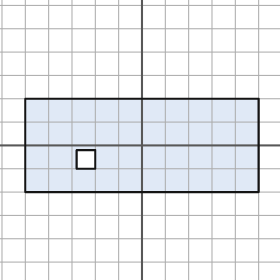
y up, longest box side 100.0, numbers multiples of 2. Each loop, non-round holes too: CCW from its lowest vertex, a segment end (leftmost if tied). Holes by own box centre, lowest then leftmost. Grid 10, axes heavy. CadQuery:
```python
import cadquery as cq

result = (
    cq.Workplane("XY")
    .moveTo(-50.0, -20.0)
    .lineTo(50.0, -20.0)
    .lineTo(50.0, 20.0)
    .lineTo(-50.0, 20.0)
    .close()
    .moveTo(-28.0, -10.0)
    .lineTo(-20.0, -10.0)
    .lineTo(-20.0, -2.0)
    .lineTo(-28.0, -2.0)
    .close()
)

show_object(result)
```